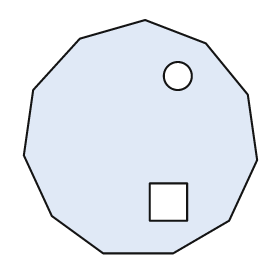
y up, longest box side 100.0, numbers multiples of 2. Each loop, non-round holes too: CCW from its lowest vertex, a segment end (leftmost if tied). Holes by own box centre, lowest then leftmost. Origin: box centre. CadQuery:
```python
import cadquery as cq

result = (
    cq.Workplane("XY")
    .moveTo(-16.0, -50.0)
    .lineTo(14.0, -50.0)
    .lineTo(38.0, -36.0)
    .lineTo(50.0, -10.0)
    .lineTo(46.0, 18.0)
    .lineTo(28.0, 40.0)
    .lineTo(2.0, 50.0)
    .lineTo(-26.0, 42.0)
    .lineTo(-46.0, 20.0)
    .lineTo(-50.0, -8.0)
    .lineTo(-38.0, -34.0)
    .close()
    .moveTo(4.0, -36.0)
    .lineTo(20.0, -36.0)
    .lineTo(20.0, -20.0)
    .lineTo(4.0, -20.0)
    .close()
    .moveTo(16.0, 26.0)
    .circle(6.0)
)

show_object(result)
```